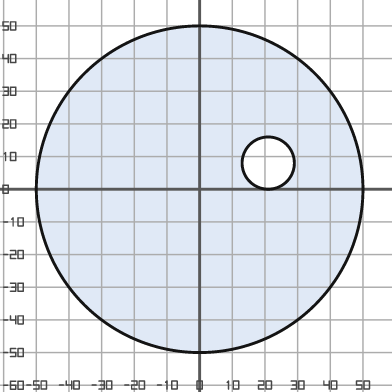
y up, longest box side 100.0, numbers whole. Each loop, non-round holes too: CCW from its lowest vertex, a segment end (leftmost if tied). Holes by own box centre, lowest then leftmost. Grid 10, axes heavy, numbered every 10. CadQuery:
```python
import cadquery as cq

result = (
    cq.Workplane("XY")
    .moveTo(0.0, 0.0)
    .circle(50.0)
    .moveTo(21.0, 8.0)
    .circle(8.0)
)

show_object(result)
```